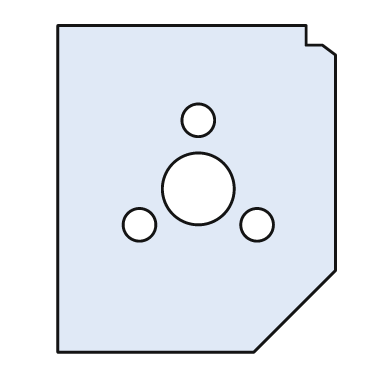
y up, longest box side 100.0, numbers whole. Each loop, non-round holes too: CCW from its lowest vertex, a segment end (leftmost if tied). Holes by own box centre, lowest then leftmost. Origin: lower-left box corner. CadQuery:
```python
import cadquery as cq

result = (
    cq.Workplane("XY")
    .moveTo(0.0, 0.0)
    .lineTo(60.0, 0.0)
    .lineTo(85.0, 25.0)
    .lineTo(85.0, 91.0)
    .lineTo(81.0, 94.0)
    .lineTo(76.0, 94.0)
    .lineTo(76.0, 100.0)
    .lineTo(0.0, 100.0)
    .close()
    .moveTo(25.0, 39.0)
    .circle(5.0)
    .moveTo(61.0, 39.0)
    .circle(5.0)
    .moveTo(43.0, 50.0)
    .circle(11.0)
    .moveTo(43.0, 71.0)
    .circle(5.0)
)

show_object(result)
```